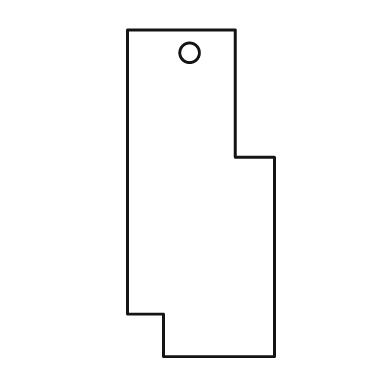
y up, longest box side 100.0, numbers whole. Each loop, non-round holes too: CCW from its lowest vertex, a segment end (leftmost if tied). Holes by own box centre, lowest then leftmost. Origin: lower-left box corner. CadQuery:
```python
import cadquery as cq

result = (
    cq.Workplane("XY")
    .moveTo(11.0, 0.0)
    .lineTo(45.0, 0.0)
    .lineTo(45.0, 61.0)
    .lineTo(33.0, 61.0)
    .lineTo(33.0, 100.0)
    .lineTo(0.0, 100.0)
    .lineTo(0.0, 13.0)
    .lineTo(11.0, 13.0)
    .close()
    .moveTo(19.0, 93.0)
    .circle(3.0)
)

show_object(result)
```